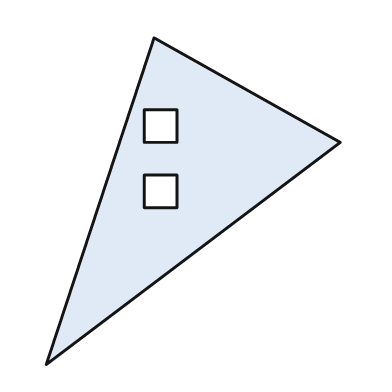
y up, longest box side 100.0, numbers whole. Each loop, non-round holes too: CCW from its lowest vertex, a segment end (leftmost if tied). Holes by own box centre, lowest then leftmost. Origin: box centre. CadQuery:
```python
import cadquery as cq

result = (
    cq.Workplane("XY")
    .moveTo(-45.0, -50.0)
    .lineTo(45.0, 18.0)
    .lineTo(-12.0, 50.0)
    .close()
    .moveTo(-15.0, -2.0)
    .lineTo(-5.0, -2.0)
    .lineTo(-5.0, 8.0)
    .lineTo(-15.0, 8.0)
    .close()
    .moveTo(-15.0, 18.0)
    .lineTo(-5.0, 18.0)
    .lineTo(-5.0, 28.0)
    .lineTo(-15.0, 28.0)
    .close()
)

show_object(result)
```